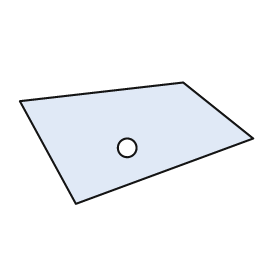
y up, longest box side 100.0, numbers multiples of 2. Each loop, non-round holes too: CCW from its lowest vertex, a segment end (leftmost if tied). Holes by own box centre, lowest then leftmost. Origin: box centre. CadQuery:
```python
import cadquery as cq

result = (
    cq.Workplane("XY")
    .moveTo(-26.0, -26.0)
    .lineTo(50.0, 2.0)
    .lineTo(20.0, 26.0)
    .lineTo(-50.0, 18.0)
    .close()
    .moveTo(-4.0, -2.0)
    .circle(4.0)
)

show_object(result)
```